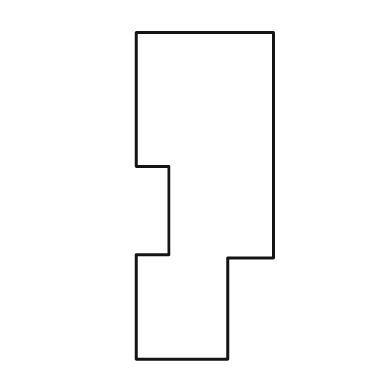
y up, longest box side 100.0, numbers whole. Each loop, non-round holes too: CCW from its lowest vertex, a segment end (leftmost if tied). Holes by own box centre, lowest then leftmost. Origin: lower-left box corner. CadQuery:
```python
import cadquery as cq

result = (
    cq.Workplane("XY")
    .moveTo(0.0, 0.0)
    .lineTo(28.0, 0.0)
    .lineTo(28.0, 31.0)
    .lineTo(42.0, 31.0)
    .lineTo(42.0, 100.0)
    .lineTo(0.0, 100.0)
    .lineTo(0.0, 59.0)
    .lineTo(10.0, 59.0)
    .lineTo(10.0, 32.0)
    .lineTo(0.0, 32.0)
    .close()
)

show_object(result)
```